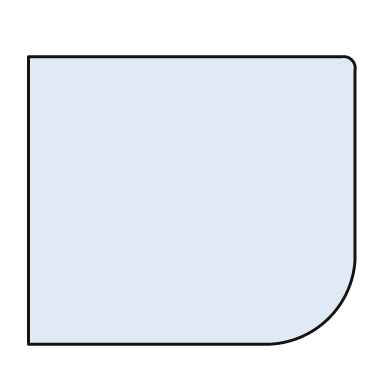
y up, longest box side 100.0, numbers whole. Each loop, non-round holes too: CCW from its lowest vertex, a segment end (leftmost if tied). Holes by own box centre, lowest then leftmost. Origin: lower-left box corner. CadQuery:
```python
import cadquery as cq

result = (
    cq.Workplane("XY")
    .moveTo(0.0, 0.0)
    .lineTo(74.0, 0.0)
    .threePointArc((92.0, 8.0), (100.0, 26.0))
    .lineTo(100.0, 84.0)
    .threePointArc((99.0, 87.0), (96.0, 88.0))
    .lineTo(0.0, 88.0)
    .close()
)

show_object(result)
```